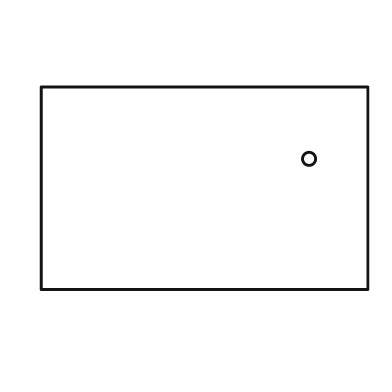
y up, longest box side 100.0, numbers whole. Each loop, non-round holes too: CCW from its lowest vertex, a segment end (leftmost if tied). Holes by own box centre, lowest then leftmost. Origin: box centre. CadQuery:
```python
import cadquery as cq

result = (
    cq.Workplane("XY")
    .moveTo(-50.0, -31.0)
    .lineTo(50.0, -31.0)
    .lineTo(50.0, 31.0)
    .lineTo(-50.0, 31.0)
    .close()
    .moveTo(32.0, 9.0)
    .circle(2.0)
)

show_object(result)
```